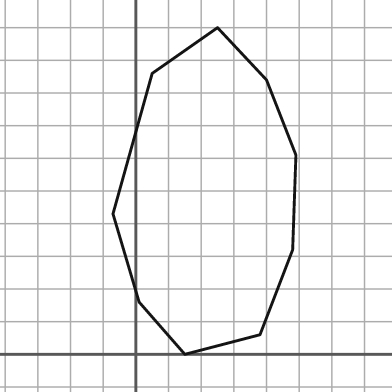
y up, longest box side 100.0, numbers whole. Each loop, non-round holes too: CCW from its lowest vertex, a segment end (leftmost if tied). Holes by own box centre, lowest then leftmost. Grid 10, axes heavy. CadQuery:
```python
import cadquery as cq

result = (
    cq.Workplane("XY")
    .moveTo(15.0, 0.0)
    .lineTo(38.0, 6.0)
    .lineTo(48.0, 32.0)
    .lineTo(49.0, 61.0)
    .lineTo(40.0, 84.0)
    .lineTo(25.0, 100.0)
    .lineTo(5.0, 86.0)
    .lineTo(-7.0, 43.0)
    .lineTo(1.0, 16.0)
    .close()
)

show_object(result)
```